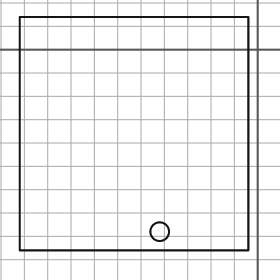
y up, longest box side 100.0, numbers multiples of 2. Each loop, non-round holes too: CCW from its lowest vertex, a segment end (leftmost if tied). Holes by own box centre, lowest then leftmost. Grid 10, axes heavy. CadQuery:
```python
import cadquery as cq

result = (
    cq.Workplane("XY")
    .moveTo(-102.0, -86.0)
    .lineTo(-4.0, -86.0)
    .lineTo(-4.0, 14.0)
    .lineTo(-102.0, 14.0)
    .close()
    .moveTo(-42.0, -78.0)
    .circle(4.0)
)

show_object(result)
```